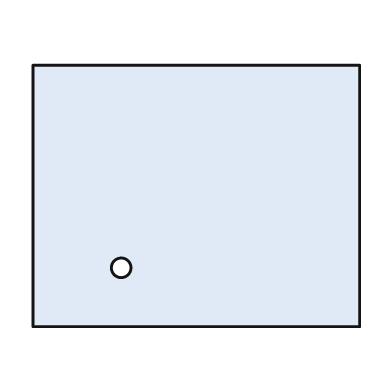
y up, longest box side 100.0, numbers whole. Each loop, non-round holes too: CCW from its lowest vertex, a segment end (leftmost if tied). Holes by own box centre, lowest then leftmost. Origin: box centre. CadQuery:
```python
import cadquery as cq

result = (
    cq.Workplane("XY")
    .moveTo(-50.0, -40.0)
    .lineTo(50.0, -40.0)
    .lineTo(50.0, 40.0)
    .lineTo(-50.0, 40.0)
    .close()
    .moveTo(-23.0, -22.0)
    .circle(3.0)
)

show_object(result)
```